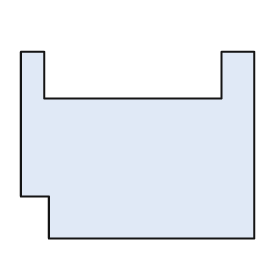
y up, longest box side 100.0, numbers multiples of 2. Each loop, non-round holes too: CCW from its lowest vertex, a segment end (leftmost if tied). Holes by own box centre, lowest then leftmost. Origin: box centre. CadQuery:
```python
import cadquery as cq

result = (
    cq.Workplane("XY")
    .moveTo(-38.0, -40.0)
    .lineTo(50.0, -40.0)
    .lineTo(50.0, 40.0)
    .lineTo(36.0, 40.0)
    .lineTo(36.0, 20.0)
    .lineTo(-40.0, 20.0)
    .lineTo(-40.0, 40.0)
    .lineTo(-50.0, 40.0)
    .lineTo(-50.0, -22.0)
    .lineTo(-38.0, -22.0)
    .close()
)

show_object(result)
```